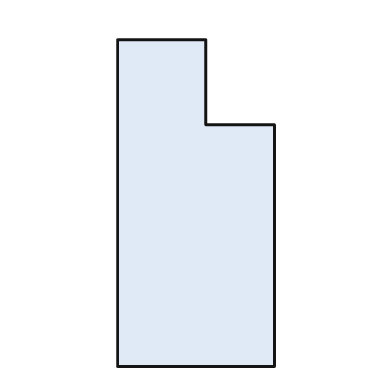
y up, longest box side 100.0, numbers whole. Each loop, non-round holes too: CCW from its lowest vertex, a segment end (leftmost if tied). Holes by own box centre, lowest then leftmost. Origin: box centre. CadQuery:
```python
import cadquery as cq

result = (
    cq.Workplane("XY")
    .moveTo(-24.0, -50.0)
    .lineTo(24.0, -50.0)
    .lineTo(24.0, 24.0)
    .lineTo(3.0, 24.0)
    .lineTo(3.0, 50.0)
    .lineTo(-24.0, 50.0)
    .close()
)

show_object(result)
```